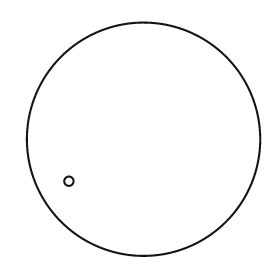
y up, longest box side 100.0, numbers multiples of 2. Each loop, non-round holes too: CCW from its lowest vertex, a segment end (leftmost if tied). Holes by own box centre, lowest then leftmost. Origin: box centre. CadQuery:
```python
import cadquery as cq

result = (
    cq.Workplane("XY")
    .moveTo(0.0, 0.0)
    .circle(50.0)
    .moveTo(-32.0, -18.0)
    .circle(2.0)
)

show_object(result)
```